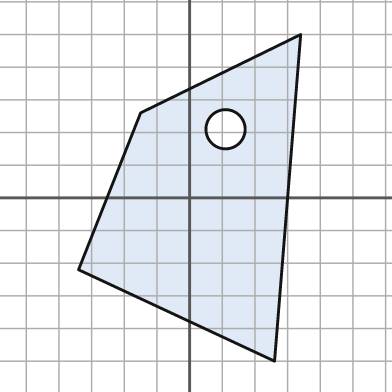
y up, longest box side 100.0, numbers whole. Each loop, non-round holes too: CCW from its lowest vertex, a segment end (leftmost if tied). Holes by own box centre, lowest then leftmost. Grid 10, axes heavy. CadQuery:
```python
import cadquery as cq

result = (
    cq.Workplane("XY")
    .moveTo(26.0, -50.0)
    .lineTo(34.0, 50.0)
    .lineTo(-15.0, 26.0)
    .lineTo(-34.0, -22.0)
    .close()
    .moveTo(11.0, 21.0)
    .circle(6.0)
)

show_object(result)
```